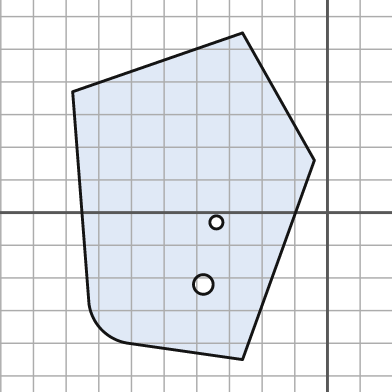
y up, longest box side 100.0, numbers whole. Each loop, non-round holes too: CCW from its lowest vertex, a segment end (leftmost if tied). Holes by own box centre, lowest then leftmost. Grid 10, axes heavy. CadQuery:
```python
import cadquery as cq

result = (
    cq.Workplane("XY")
    .moveTo(-26.0, -45.0)
    .lineTo(-4.0, 16.0)
    .lineTo(-26.0, 55.0)
    .lineTo(-78.0, 37.0)
    .lineTo(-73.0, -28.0)
    .threePointArc((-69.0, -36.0), (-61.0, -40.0))
    .close()
    .moveTo(-38.0, -22.0)
    .circle(3.0)
    .moveTo(-34.0, -3.0)
    .circle(2.0)
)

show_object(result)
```